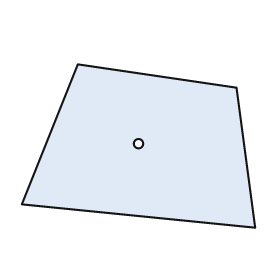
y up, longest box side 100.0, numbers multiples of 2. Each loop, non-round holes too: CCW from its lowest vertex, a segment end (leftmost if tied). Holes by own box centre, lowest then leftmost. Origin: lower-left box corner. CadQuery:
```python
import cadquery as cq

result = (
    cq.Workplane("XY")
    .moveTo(100.0, 0.0)
    .lineTo(92.0, 60.0)
    .lineTo(24.0, 70.0)
    .lineTo(0.0, 10.0)
    .close()
    .moveTo(50.0, 36.0)
    .circle(2.0)
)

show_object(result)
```